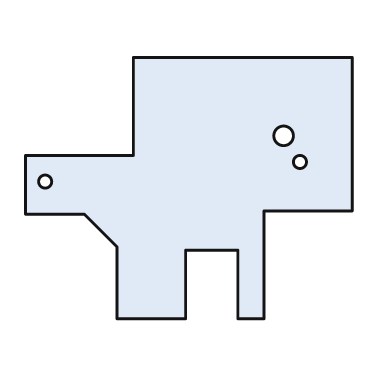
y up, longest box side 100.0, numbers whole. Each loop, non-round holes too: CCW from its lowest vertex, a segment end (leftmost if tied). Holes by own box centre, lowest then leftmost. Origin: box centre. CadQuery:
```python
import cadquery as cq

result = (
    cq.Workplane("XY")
    .moveTo(-22.0, -40.0)
    .lineTo(-1.0, -40.0)
    .lineTo(-1.0, -19.0)
    .lineTo(15.0, -19.0)
    .lineTo(15.0, -40.0)
    .lineTo(23.0, -40.0)
    .lineTo(23.0, -7.0)
    .lineTo(50.0, -7.0)
    .lineTo(50.0, 40.0)
    .lineTo(-17.0, 40.0)
    .lineTo(-17.0, 10.0)
    .lineTo(-50.0, 10.0)
    .lineTo(-50.0, -8.0)
    .lineTo(-32.0, -8.0)
    .lineTo(-22.0, -18.0)
    .close()
    .moveTo(-44.0, 2.0)
    .circle(2.0)
    .moveTo(34.0, 8.0)
    .circle(2.0)
    .moveTo(29.0, 16.0)
    .circle(3.0)
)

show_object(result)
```